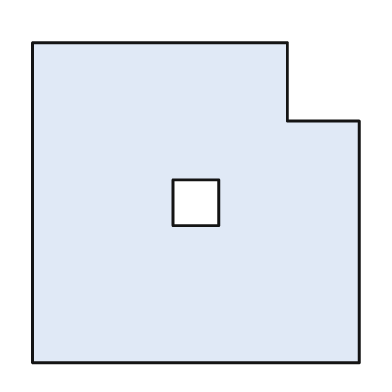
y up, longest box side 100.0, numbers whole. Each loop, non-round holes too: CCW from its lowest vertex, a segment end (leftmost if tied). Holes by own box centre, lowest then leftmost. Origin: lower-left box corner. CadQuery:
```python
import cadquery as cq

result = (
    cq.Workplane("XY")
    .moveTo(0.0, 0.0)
    .lineTo(100.0, 0.0)
    .lineTo(100.0, 74.0)
    .lineTo(78.0, 74.0)
    .lineTo(78.0, 98.0)
    .lineTo(0.0, 98.0)
    .close()
    .moveTo(43.0, 42.0)
    .lineTo(57.0, 42.0)
    .lineTo(57.0, 56.0)
    .lineTo(43.0, 56.0)
    .close()
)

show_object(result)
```